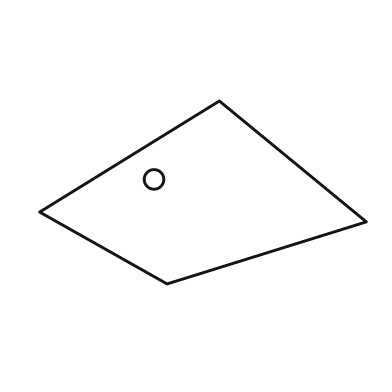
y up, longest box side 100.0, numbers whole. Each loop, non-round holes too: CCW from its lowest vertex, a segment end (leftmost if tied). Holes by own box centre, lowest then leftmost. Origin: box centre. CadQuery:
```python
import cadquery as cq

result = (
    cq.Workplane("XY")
    .moveTo(-11.0, -28.0)
    .lineTo(50.0, -9.0)
    .lineTo(5.0, 28.0)
    .lineTo(-50.0, -6.0)
    .close()
    .moveTo(-15.0, 4.0)
    .circle(3.0)
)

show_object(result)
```